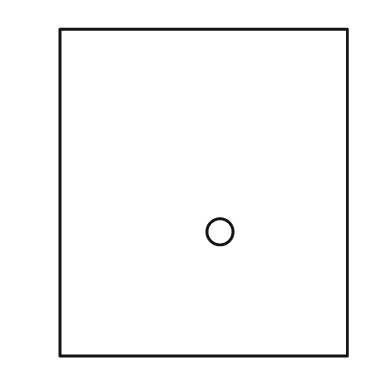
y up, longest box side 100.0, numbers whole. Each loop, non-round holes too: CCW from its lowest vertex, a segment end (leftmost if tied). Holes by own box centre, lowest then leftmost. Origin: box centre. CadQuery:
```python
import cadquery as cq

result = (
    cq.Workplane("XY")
    .moveTo(-44.0, -50.0)
    .lineTo(44.0, -50.0)
    .lineTo(44.0, 50.0)
    .lineTo(-44.0, 50.0)
    .close()
    .moveTo(5.0, -12.0)
    .circle(4.0)
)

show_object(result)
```